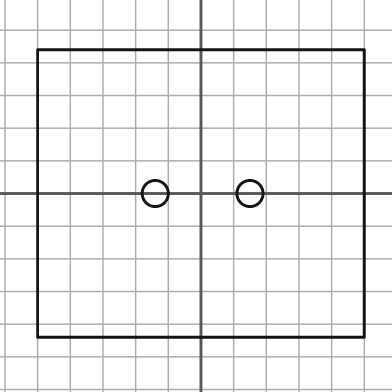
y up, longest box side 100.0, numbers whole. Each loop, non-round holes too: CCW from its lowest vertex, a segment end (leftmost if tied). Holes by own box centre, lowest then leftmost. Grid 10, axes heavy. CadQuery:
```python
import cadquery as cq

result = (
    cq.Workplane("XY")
    .moveTo(-50.0, -44.0)
    .lineTo(50.0, -44.0)
    .lineTo(50.0, 44.0)
    .lineTo(-50.0, 44.0)
    .close()
    .moveTo(-14.0, 0.0)
    .circle(4.0)
    .moveTo(15.0, 0.0)
    .circle(4.0)
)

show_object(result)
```